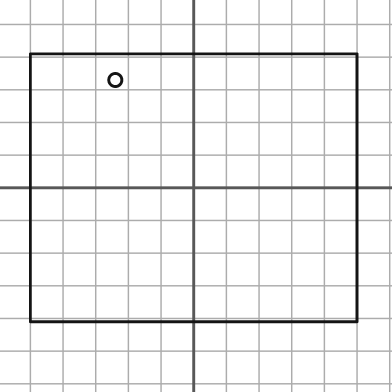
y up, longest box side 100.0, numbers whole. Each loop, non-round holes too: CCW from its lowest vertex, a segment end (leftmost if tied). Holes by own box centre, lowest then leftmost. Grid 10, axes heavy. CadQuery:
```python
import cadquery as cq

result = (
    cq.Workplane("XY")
    .moveTo(-50.0, -41.0)
    .lineTo(50.0, -41.0)
    .lineTo(50.0, 41.0)
    .lineTo(-50.0, 41.0)
    .close()
    .moveTo(-24.0, 33.0)
    .circle(2.0)
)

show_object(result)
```